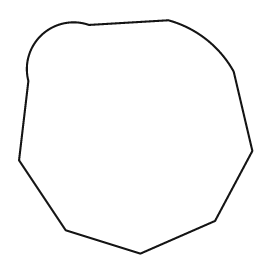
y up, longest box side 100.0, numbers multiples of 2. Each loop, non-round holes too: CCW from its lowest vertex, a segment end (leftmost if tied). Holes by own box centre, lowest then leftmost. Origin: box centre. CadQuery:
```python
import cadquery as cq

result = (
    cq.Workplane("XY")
    .moveTo(2.0, -50.0)
    .lineTo(34.0, -36.0)
    .lineTo(50.0, -6.0)
    .lineTo(42.0, 28.0)
    .threePointArc((30.0, 42.0), (14.0, 50.0))
    .lineTo(-20.0, 48.0)
    .threePointArc((-40.0, 44.0), (-46.0, 24.0))
    .lineTo(-50.0, -10.0)
    .lineTo(-30.0, -40.0)
    .close()
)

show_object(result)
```